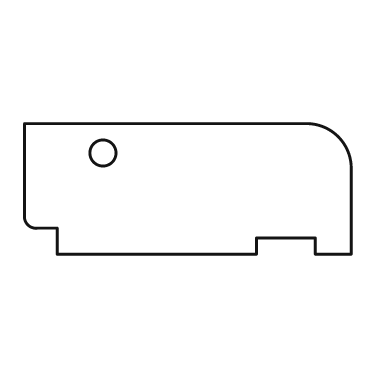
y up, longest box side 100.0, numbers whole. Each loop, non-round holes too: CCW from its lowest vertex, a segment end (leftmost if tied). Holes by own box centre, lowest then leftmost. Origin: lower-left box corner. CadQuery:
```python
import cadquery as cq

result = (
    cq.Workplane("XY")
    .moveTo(10.0, 0.0)
    .lineTo(71.0, 0.0)
    .lineTo(71.0, 5.0)
    .lineTo(89.0, 5.0)
    .lineTo(89.0, 0.0)
    .lineTo(100.0, 0.0)
    .lineTo(100.0, 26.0)
    .threePointArc((96.0, 36.0), (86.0, 40.0))
    .lineTo(0.0, 40.0)
    .lineTo(0.0, 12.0)
    .threePointArc((1.0, 9.0), (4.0, 8.0))
    .lineTo(10.0, 8.0)
    .close()
    .moveTo(24.0, 31.0)
    .circle(4.0)
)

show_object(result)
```